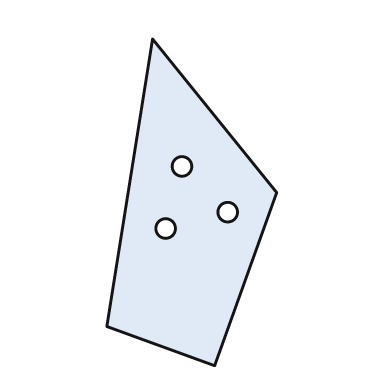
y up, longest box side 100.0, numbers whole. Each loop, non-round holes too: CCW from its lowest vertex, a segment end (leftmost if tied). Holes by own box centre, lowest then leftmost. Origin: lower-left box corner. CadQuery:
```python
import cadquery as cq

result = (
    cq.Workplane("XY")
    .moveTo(33.0, 0.0)
    .lineTo(52.0, 53.0)
    .lineTo(14.0, 100.0)
    .lineTo(0.0, 12.0)
    .close()
    .moveTo(18.0, 42.0)
    .circle(3.0)
    .moveTo(37.0, 47.0)
    .circle(3.0)
    .moveTo(23.0, 61.0)
    .circle(3.0)
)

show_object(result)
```